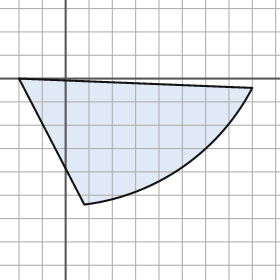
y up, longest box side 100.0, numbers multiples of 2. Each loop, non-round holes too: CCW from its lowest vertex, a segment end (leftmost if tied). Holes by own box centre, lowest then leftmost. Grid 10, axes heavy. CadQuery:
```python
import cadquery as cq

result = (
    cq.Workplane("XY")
    .moveTo(8.0, -54.0)
    .threePointArc((50.0, -38.0), (80.0, -4.0))
    .lineTo(-20.0, 0.0)
    .close()
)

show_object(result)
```